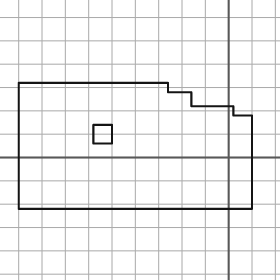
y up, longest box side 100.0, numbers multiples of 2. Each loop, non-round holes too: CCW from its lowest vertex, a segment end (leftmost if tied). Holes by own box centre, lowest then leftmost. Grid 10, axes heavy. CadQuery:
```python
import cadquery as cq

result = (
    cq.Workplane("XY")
    .moveTo(-90.0, -22.0)
    .lineTo(10.0, -22.0)
    .lineTo(10.0, 18.0)
    .lineTo(2.0, 18.0)
    .lineTo(2.0, 22.0)
    .lineTo(-16.0, 22.0)
    .lineTo(-16.0, 28.0)
    .lineTo(-26.0, 28.0)
    .lineTo(-26.0, 32.0)
    .lineTo(-90.0, 32.0)
    .close()
    .moveTo(-58.0, 6.0)
    .lineTo(-50.0, 6.0)
    .lineTo(-50.0, 14.0)
    .lineTo(-58.0, 14.0)
    .close()
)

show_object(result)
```